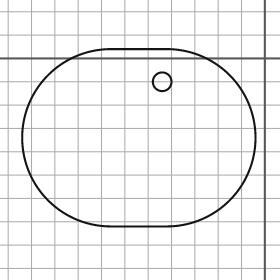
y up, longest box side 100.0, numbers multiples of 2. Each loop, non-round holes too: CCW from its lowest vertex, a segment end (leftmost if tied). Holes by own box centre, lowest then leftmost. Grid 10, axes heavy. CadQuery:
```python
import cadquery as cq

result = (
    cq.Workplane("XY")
    .moveTo(-66.0, -72.0)
    .lineTo(-42.0, -72.0)
    .threePointArc((-4.0, -34.0), (-42.0, 4.0))
    .lineTo(-66.0, 4.0)
    .threePointArc((-104.0, -34.0), (-66.0, -72.0))
    .close()
    .moveTo(-44.0, -10.0)
    .circle(4.0)
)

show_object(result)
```